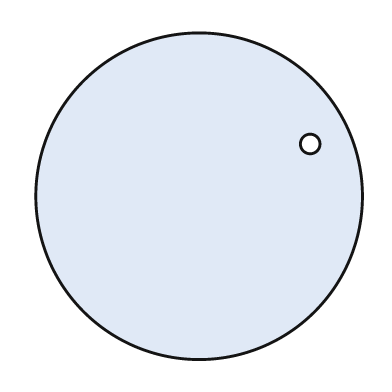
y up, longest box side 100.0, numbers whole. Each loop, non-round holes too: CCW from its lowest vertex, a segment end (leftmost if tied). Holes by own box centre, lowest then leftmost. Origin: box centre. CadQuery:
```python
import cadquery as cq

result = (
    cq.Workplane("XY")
    .moveTo(0.0, 0.0)
    .circle(50.0)
    .moveTo(34.0, 16.0)
    .circle(3.0)
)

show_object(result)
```